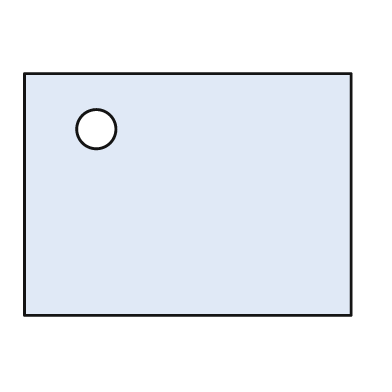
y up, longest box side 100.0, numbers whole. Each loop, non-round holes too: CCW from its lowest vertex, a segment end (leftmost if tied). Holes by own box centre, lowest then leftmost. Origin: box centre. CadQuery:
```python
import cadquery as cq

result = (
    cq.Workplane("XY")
    .moveTo(-50.0, -37.0)
    .lineTo(50.0, -37.0)
    .lineTo(50.0, 37.0)
    .lineTo(-50.0, 37.0)
    .close()
    .moveTo(-28.0, 20.0)
    .circle(6.0)
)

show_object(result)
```